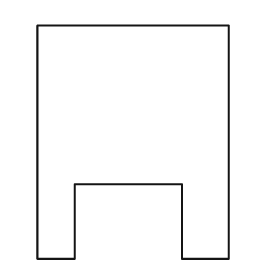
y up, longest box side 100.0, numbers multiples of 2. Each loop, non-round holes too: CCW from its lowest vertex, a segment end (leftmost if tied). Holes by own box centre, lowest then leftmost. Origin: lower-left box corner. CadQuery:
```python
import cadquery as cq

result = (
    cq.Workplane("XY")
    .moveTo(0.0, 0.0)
    .lineTo(16.0, 0.0)
    .lineTo(16.0, 32.0)
    .lineTo(62.0, 32.0)
    .lineTo(62.0, 0.0)
    .lineTo(82.0, 0.0)
    .lineTo(82.0, 100.0)
    .lineTo(0.0, 100.0)
    .close()
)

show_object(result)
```